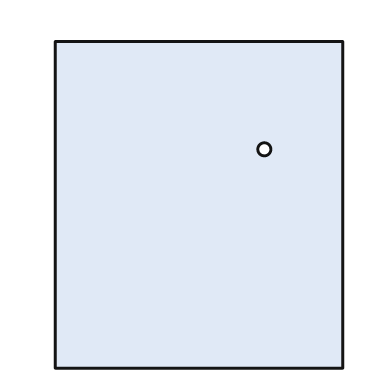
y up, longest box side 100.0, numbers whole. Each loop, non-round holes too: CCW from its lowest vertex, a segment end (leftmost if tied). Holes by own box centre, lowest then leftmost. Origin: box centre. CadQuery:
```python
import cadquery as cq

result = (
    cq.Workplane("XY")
    .moveTo(-44.0, -50.0)
    .lineTo(44.0, -50.0)
    .lineTo(44.0, 50.0)
    .lineTo(-44.0, 50.0)
    .close()
    .moveTo(20.0, 17.0)
    .circle(2.0)
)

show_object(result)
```